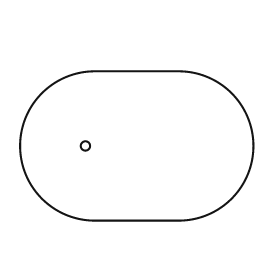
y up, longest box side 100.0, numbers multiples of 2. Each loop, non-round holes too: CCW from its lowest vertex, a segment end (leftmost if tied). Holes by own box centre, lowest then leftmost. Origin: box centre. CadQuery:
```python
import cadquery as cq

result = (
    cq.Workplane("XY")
    .moveTo(-18.0, -32.0)
    .lineTo(18.0, -32.0)
    .threePointArc((50.0, 0.0), (18.0, 32.0))
    .lineTo(-18.0, 32.0)
    .threePointArc((-50.0, 0.0), (-18.0, -32.0))
    .close()
    .moveTo(-22.0, 0.0)
    .circle(2.0)
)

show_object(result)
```